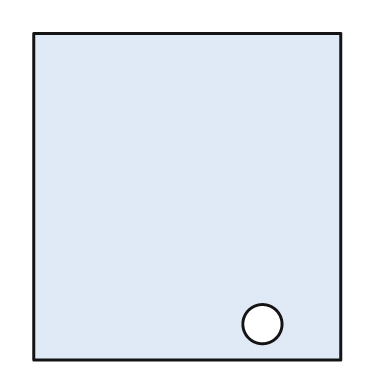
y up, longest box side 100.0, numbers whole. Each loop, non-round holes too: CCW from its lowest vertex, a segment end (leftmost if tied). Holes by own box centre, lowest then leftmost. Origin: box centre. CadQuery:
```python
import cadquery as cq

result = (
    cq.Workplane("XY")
    .moveTo(-47.0, -50.0)
    .lineTo(47.0, -50.0)
    .lineTo(47.0, 50.0)
    .lineTo(-47.0, 50.0)
    .close()
    .moveTo(23.0, -39.0)
    .circle(6.0)
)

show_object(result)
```